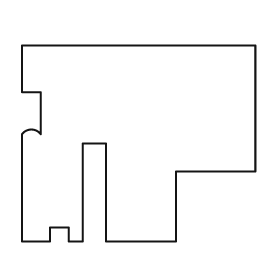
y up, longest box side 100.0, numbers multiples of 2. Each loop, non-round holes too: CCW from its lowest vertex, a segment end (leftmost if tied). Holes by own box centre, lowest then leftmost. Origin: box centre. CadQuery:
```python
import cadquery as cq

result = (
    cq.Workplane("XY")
    .moveTo(-50.0, -42.0)
    .lineTo(-38.0, -42.0)
    .lineTo(-38.0, -36.0)
    .lineTo(-30.0, -36.0)
    .lineTo(-30.0, -42.0)
    .lineTo(-24.0, -42.0)
    .lineTo(-24.0, 0.0)
    .lineTo(-14.0, 0.0)
    .lineTo(-14.0, -42.0)
    .lineTo(16.0, -42.0)
    .lineTo(16.0, -12.0)
    .lineTo(50.0, -12.0)
    .lineTo(50.0, 42.0)
    .lineTo(-50.0, 42.0)
    .lineTo(-50.0, 22.0)
    .lineTo(-42.0, 22.0)
    .lineTo(-42.0, 4.0)
    .threePointArc((-46.0, 6.0), (-50.0, 4.0))
    .close()
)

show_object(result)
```